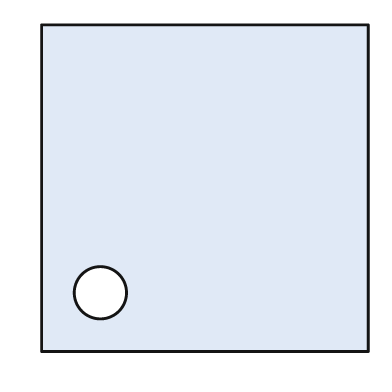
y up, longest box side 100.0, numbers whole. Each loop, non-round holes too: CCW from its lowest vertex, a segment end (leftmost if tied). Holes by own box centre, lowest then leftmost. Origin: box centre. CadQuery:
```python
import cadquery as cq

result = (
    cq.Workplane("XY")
    .moveTo(-50.0, -50.0)
    .lineTo(50.0, -50.0)
    .lineTo(50.0, 50.0)
    .lineTo(-50.0, 50.0)
    .close()
    .moveTo(-32.0, -32.0)
    .circle(8.0)
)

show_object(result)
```